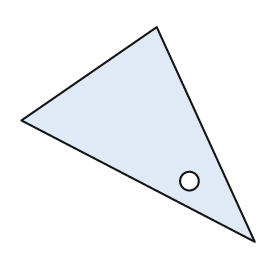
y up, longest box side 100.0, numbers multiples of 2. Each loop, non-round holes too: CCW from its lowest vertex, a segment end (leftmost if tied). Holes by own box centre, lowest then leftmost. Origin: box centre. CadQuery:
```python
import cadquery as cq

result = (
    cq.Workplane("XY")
    .moveTo(50.0, -46.0)
    .lineTo(8.0, 46.0)
    .lineTo(-50.0, 6.0)
    .close()
    .moveTo(22.0, -20.0)
    .circle(4.0)
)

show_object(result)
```